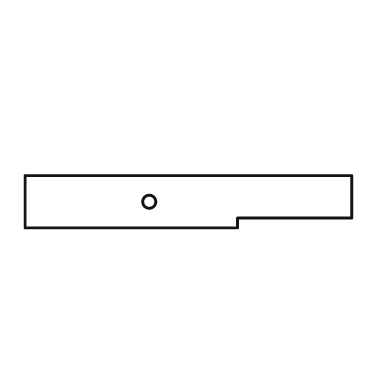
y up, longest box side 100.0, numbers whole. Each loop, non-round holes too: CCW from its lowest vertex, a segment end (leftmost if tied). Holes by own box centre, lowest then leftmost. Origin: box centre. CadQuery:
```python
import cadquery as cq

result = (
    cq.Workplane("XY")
    .moveTo(-50.0, -8.0)
    .lineTo(15.0, -8.0)
    .lineTo(15.0, -5.0)
    .lineTo(50.0, -5.0)
    .lineTo(50.0, 8.0)
    .lineTo(-50.0, 8.0)
    .close()
    .moveTo(-12.0, 0.0)
    .circle(2.0)
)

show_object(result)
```